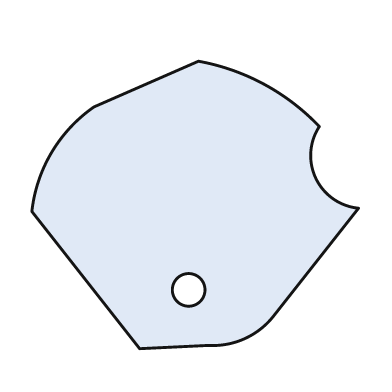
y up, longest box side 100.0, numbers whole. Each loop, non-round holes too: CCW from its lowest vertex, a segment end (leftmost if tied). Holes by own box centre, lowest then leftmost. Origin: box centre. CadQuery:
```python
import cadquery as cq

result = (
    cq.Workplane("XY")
    .moveTo(-17.0, -44.0)
    .lineTo(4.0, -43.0)
    .threePointArc((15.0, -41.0), (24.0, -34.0))
    .lineTo(50.0, -1.0)
    .threePointArc((37.0, 8.0), (38.0, 24.0))
    .threePointArc((21.0, 37.0), (1.0, 44.0))
    .lineTo(-31.0, 30.0)
    .threePointArc((-44.0, 16.0), (-50.0, -2.0))
    .close()
    .moveTo(-2.0, -26.0)
    .circle(5.0)
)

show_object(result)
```